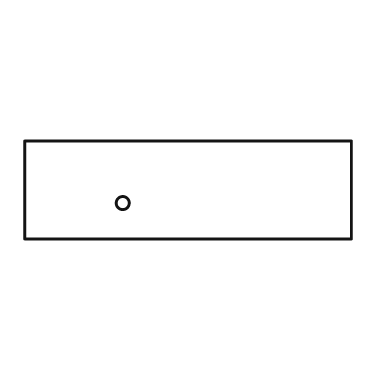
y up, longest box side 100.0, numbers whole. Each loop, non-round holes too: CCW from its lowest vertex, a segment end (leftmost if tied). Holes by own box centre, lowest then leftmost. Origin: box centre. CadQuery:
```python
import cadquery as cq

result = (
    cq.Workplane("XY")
    .moveTo(-50.0, -15.0)
    .lineTo(50.0, -15.0)
    .lineTo(50.0, 15.0)
    .lineTo(-50.0, 15.0)
    .close()
    .moveTo(-20.0, -4.0)
    .circle(2.0)
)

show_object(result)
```